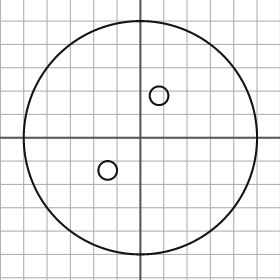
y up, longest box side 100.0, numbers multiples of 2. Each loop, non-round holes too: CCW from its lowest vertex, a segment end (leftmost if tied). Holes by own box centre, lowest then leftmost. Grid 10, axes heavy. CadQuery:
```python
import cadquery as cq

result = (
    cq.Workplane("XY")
    .moveTo(0.0, 0.0)
    .circle(50.0)
    .moveTo(-14.0, -14.0)
    .circle(4.0)
    .moveTo(8.0, 18.0)
    .circle(4.0)
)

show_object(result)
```